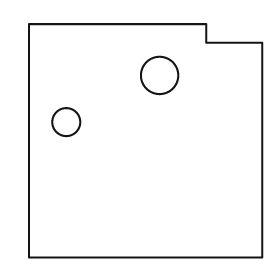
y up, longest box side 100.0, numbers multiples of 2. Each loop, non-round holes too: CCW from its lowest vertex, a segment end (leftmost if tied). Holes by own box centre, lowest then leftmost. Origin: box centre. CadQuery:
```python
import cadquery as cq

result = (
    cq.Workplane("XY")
    .moveTo(-50.0, -50.0)
    .lineTo(50.0, -50.0)
    .lineTo(50.0, 42.0)
    .lineTo(26.0, 42.0)
    .lineTo(26.0, 50.0)
    .lineTo(-50.0, 50.0)
    .close()
    .moveTo(-34.0, 8.0)
    .circle(6.0)
    .moveTo(6.0, 28.0)
    .circle(8.0)
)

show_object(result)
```